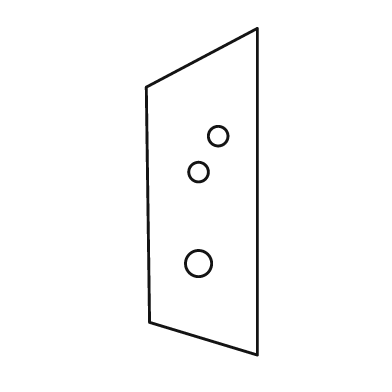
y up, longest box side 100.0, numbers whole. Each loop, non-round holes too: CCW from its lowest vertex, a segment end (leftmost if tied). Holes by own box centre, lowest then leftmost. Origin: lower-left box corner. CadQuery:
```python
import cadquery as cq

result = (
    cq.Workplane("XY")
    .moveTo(34.0, 0.0)
    .lineTo(34.0, 100.0)
    .lineTo(0.0, 82.0)
    .lineTo(1.0, 10.0)
    .close()
    .moveTo(16.0, 28.0)
    .circle(4.0)
    .moveTo(16.0, 56.0)
    .circle(3.0)
    .moveTo(22.0, 67.0)
    .circle(3.0)
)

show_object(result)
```